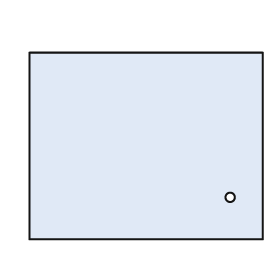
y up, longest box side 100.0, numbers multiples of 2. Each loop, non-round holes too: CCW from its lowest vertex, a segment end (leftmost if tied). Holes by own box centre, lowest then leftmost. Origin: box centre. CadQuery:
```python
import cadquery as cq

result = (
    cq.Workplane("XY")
    .moveTo(-50.0, -40.0)
    .lineTo(50.0, -40.0)
    .lineTo(50.0, 40.0)
    .lineTo(-50.0, 40.0)
    .close()
    .moveTo(36.0, -22.0)
    .circle(2.0)
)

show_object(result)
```